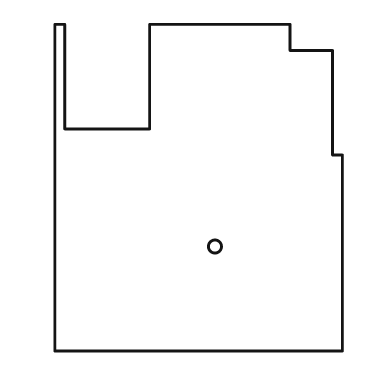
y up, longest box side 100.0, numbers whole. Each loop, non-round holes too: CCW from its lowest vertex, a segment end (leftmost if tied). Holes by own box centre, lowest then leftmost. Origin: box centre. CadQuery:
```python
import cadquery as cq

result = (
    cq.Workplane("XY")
    .moveTo(-44.0, -50.0)
    .lineTo(44.0, -50.0)
    .lineTo(44.0, 10.0)
    .lineTo(41.0, 10.0)
    .lineTo(41.0, 42.0)
    .lineTo(28.0, 42.0)
    .lineTo(28.0, 50.0)
    .lineTo(-15.0, 50.0)
    .lineTo(-15.0, 18.0)
    .lineTo(-41.0, 18.0)
    .lineTo(-41.0, 50.0)
    .lineTo(-44.0, 50.0)
    .close()
    .moveTo(5.0, -18.0)
    .circle(2.0)
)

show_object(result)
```